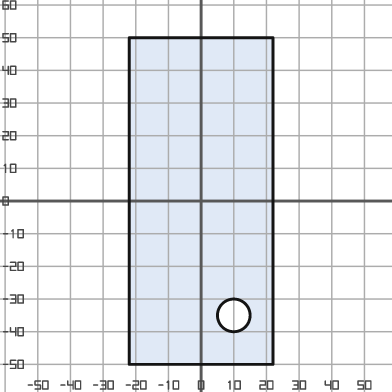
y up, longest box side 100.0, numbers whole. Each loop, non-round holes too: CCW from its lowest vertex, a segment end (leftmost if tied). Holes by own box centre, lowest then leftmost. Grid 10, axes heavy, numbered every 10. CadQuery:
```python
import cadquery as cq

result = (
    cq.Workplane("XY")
    .moveTo(-22.0, -50.0)
    .lineTo(22.0, -50.0)
    .lineTo(22.0, 50.0)
    .lineTo(-22.0, 50.0)
    .close()
    .moveTo(10.0, -35.0)
    .circle(5.0)
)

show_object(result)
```